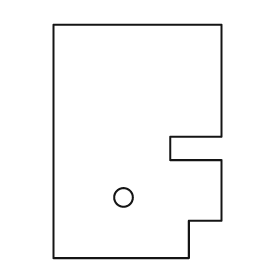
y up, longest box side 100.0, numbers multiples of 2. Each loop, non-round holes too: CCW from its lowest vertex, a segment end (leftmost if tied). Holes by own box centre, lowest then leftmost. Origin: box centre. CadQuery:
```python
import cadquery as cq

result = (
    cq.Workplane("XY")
    .moveTo(-36.0, -50.0)
    .lineTo(22.0, -50.0)
    .lineTo(22.0, -34.0)
    .lineTo(36.0, -34.0)
    .lineTo(36.0, -8.0)
    .lineTo(14.0, -8.0)
    .lineTo(14.0, 2.0)
    .lineTo(36.0, 2.0)
    .lineTo(36.0, 50.0)
    .lineTo(-36.0, 50.0)
    .close()
    .moveTo(-6.0, -24.0)
    .circle(4.0)
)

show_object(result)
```